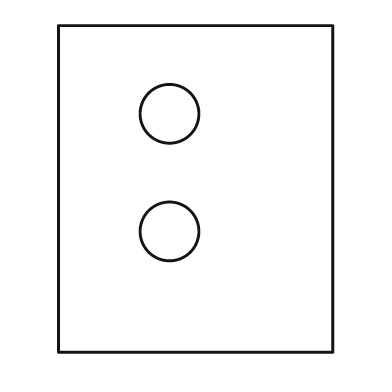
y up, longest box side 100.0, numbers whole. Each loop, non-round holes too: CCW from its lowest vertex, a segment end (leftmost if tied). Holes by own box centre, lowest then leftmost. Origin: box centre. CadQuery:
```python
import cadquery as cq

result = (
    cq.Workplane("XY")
    .moveTo(-42.0, -50.0)
    .lineTo(42.0, -50.0)
    .lineTo(42.0, 50.0)
    .lineTo(-42.0, 50.0)
    .close()
    .moveTo(-8.0, -13.0)
    .circle(9.0)
    .moveTo(-8.0, 23.0)
    .circle(9.0)
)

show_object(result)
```